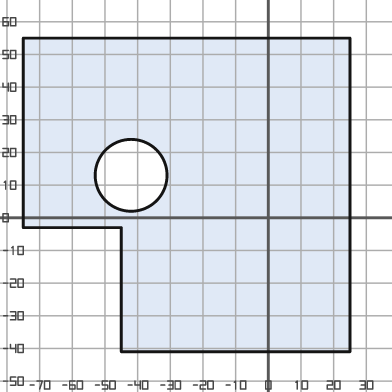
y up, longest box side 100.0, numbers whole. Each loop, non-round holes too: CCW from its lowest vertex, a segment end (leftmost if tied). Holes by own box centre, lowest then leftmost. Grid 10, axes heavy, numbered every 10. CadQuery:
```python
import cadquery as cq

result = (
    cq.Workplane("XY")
    .moveTo(-45.0, -41.0)
    .lineTo(25.0, -41.0)
    .lineTo(25.0, 55.0)
    .lineTo(-75.0, 55.0)
    .lineTo(-75.0, -3.0)
    .lineTo(-45.0, -3.0)
    .close()
    .moveTo(-42.0, 13.0)
    .circle(11.0)
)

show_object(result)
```